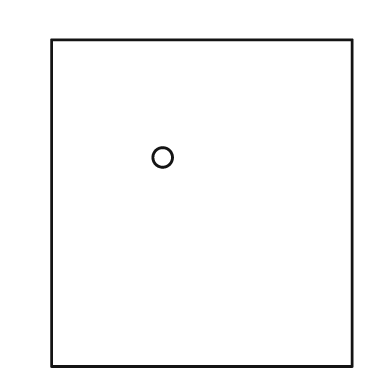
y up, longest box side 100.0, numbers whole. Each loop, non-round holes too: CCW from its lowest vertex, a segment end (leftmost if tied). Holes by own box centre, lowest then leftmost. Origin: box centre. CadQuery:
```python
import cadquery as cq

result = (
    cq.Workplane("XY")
    .moveTo(-46.0, -50.0)
    .lineTo(46.0, -50.0)
    .lineTo(46.0, 50.0)
    .lineTo(-46.0, 50.0)
    .close()
    .moveTo(-12.0, 14.0)
    .circle(3.0)
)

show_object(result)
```